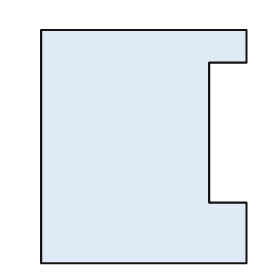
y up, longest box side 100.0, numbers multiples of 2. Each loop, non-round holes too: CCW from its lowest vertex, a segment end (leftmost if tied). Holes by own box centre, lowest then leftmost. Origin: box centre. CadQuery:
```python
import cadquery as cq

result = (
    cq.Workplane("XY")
    .moveTo(-44.0, -50.0)
    .lineTo(44.0, -50.0)
    .lineTo(44.0, -24.0)
    .lineTo(28.0, -24.0)
    .lineTo(28.0, 36.0)
    .lineTo(44.0, 36.0)
    .lineTo(44.0, 50.0)
    .lineTo(-44.0, 50.0)
    .close()
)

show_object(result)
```